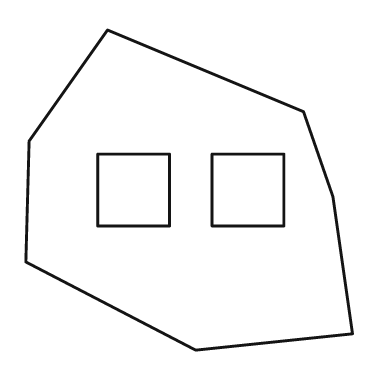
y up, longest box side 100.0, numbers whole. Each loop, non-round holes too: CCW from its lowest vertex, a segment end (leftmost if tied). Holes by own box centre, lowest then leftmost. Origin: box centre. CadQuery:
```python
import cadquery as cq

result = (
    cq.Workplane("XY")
    .moveTo(2.0, -49.0)
    .lineTo(50.0, -44.0)
    .lineTo(44.0, -2.0)
    .lineTo(35.0, 24.0)
    .lineTo(-25.0, 49.0)
    .lineTo(-49.0, 15.0)
    .lineTo(-50.0, -22.0)
    .close()
    .moveTo(-28.0, -11.0)
    .lineTo(-6.0, -11.0)
    .lineTo(-6.0, 11.0)
    .lineTo(-28.0, 11.0)
    .close()
    .moveTo(7.0, -11.0)
    .lineTo(29.0, -11.0)
    .lineTo(29.0, 11.0)
    .lineTo(7.0, 11.0)
    .close()
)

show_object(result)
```